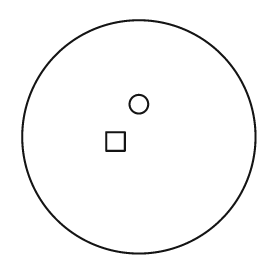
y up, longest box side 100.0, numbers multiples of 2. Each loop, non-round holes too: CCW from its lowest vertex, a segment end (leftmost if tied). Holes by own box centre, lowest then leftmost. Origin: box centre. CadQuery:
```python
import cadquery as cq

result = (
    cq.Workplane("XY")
    .moveTo(0.0, 0.0)
    .circle(50.0)
    .moveTo(-14.0, -6.0)
    .lineTo(-6.0, -6.0)
    .lineTo(-6.0, 2.0)
    .lineTo(-14.0, 2.0)
    .close()
    .moveTo(0.0, 14.0)
    .circle(4.0)
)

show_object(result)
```